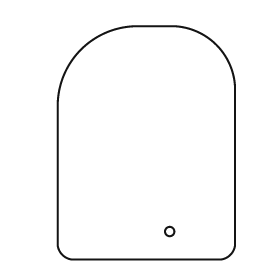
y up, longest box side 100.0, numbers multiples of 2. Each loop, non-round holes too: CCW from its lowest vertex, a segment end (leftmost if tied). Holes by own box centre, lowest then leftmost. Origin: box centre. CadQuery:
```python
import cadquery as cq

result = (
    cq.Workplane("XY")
    .moveTo(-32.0, -50.0)
    .lineTo(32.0, -50.0)
    .threePointArc((36.0, -48.0), (38.0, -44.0))
    .lineTo(38.0, 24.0)
    .threePointArc((30.0, 42.0), (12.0, 50.0))
    .lineTo(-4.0, 50.0)
    .threePointArc((-28.0, 40.0), (-38.0, 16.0))
    .lineTo(-38.0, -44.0)
    .threePointArc((-36.0, -48.0), (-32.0, -50.0))
    .close()
    .moveTo(10.0, -38.0)
    .circle(2.0)
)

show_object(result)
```